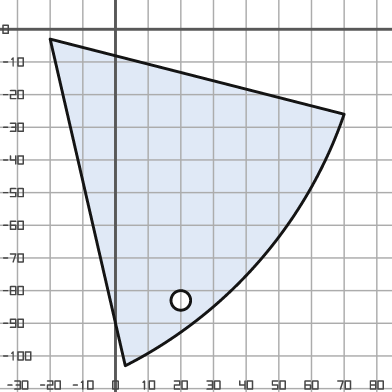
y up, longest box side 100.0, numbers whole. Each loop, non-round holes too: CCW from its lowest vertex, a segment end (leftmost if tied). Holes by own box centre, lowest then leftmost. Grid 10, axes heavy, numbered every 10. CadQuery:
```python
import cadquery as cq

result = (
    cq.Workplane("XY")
    .moveTo(3.0, -103.0)
    .threePointArc((44.0, -71.0), (70.0, -26.0))
    .lineTo(-20.0, -3.0)
    .close()
    .moveTo(20.0, -83.0)
    .circle(3.0)
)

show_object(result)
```